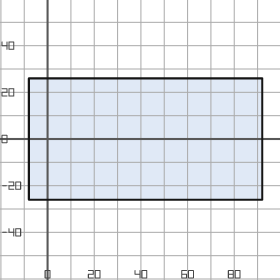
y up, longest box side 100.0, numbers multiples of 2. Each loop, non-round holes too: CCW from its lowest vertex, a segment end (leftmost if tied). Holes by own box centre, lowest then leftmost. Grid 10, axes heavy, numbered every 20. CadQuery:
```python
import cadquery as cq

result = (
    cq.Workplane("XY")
    .moveTo(-8.0, -26.0)
    .lineTo(92.0, -26.0)
    .lineTo(92.0, 26.0)
    .lineTo(-8.0, 26.0)
    .close()
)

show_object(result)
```